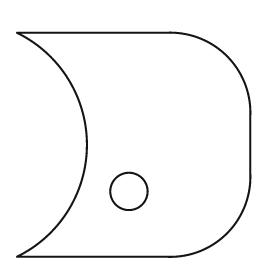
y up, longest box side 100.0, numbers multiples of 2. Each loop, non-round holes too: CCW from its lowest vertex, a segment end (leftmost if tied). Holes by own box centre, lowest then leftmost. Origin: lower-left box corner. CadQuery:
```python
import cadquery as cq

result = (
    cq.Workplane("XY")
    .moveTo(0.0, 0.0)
    .lineTo(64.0, 0.0)
    .threePointArc((90.0, 10.0), (100.0, 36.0))
    .lineTo(100.0, 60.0)
    .threePointArc((90.0, 86.0), (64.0, 96.0))
    .lineTo(0.0, 96.0)
    .threePointArc((30.0, 48.0), (0.0, 0.0))
    .close()
    .moveTo(48.0, 28.0)
    .circle(8.0)
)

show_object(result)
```